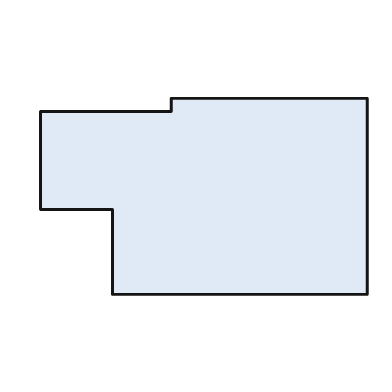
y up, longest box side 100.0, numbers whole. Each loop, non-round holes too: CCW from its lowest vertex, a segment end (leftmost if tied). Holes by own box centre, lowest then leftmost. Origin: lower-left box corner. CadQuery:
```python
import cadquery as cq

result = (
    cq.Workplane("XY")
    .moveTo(22.0, 0.0)
    .lineTo(100.0, 0.0)
    .lineTo(100.0, 60.0)
    .lineTo(40.0, 60.0)
    .lineTo(40.0, 56.0)
    .lineTo(0.0, 56.0)
    .lineTo(0.0, 26.0)
    .lineTo(22.0, 26.0)
    .close()
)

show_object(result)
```